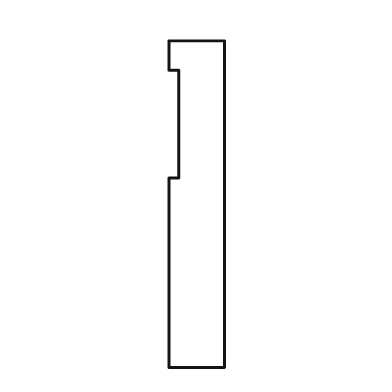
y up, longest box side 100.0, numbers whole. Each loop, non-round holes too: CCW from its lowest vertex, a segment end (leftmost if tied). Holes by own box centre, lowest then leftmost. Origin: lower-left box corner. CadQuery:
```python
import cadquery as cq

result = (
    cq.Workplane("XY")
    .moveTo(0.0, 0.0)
    .lineTo(17.0, 0.0)
    .lineTo(17.0, 100.0)
    .lineTo(0.0, 100.0)
    .lineTo(0.0, 91.0)
    .lineTo(3.0, 91.0)
    .lineTo(3.0, 58.0)
    .lineTo(0.0, 58.0)
    .close()
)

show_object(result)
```